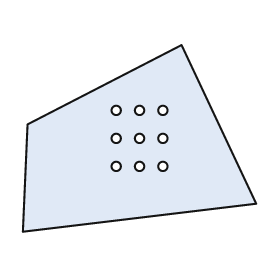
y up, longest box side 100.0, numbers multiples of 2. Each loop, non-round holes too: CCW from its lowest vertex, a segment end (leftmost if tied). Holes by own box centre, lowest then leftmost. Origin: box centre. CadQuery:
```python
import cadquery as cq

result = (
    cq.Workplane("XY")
    .moveTo(-50.0, -40.0)
    .lineTo(50.0, -28.0)
    .lineTo(18.0, 40.0)
    .lineTo(-48.0, 6.0)
    .close()
    .moveTo(-10.0, -12.0)
    .circle(2.0)
    .moveTo(0.0, -12.0)
    .circle(2.0)
    .moveTo(10.0, -12.0)
    .circle(2.0)
    .moveTo(-10.0, 0.0)
    .circle(2.0)
    .moveTo(0.0, 0.0)
    .circle(2.0)
    .moveTo(10.0, 0.0)
    .circle(2.0)
    .moveTo(-10.0, 12.0)
    .circle(2.0)
    .moveTo(0.0, 12.0)
    .circle(2.0)
    .moveTo(10.0, 12.0)
    .circle(2.0)
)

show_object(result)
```